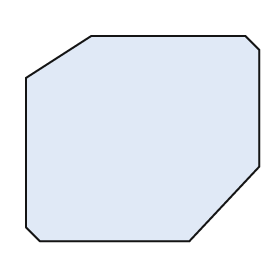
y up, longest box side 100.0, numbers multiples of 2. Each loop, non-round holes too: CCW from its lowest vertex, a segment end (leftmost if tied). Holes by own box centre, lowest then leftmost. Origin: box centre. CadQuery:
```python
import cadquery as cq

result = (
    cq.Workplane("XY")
    .moveTo(-44.0, -44.0)
    .lineTo(20.0, -44.0)
    .lineTo(50.0, -12.0)
    .lineTo(50.0, 38.0)
    .lineTo(44.0, 44.0)
    .lineTo(-22.0, 44.0)
    .lineTo(-50.0, 26.0)
    .lineTo(-50.0, -38.0)
    .close()
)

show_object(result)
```